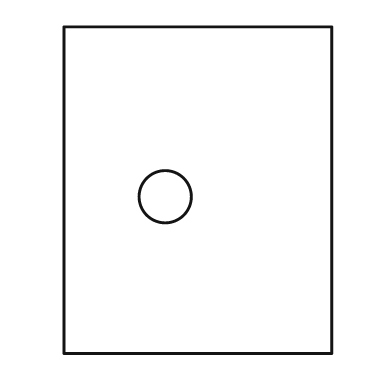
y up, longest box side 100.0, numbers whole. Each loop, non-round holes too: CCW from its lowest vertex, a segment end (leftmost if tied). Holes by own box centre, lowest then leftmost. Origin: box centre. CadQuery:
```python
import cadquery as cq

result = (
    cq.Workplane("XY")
    .moveTo(-41.0, -50.0)
    .lineTo(41.0, -50.0)
    .lineTo(41.0, 50.0)
    .lineTo(-41.0, 50.0)
    .close()
    .moveTo(-10.0, -2.0)
    .circle(8.0)
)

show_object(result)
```